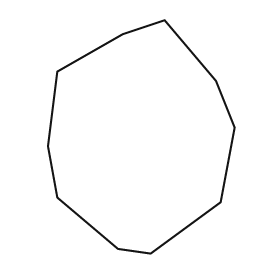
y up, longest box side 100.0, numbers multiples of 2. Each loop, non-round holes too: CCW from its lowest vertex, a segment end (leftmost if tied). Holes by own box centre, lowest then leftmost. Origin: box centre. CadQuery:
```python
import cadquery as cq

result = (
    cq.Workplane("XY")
    .moveTo(4.0, -50.0)
    .lineTo(34.0, -28.0)
    .lineTo(40.0, 4.0)
    .lineTo(32.0, 24.0)
    .lineTo(10.0, 50.0)
    .lineTo(-8.0, 44.0)
    .lineTo(-36.0, 28.0)
    .lineTo(-40.0, -4.0)
    .lineTo(-36.0, -26.0)
    .lineTo(-10.0, -48.0)
    .close()
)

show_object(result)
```